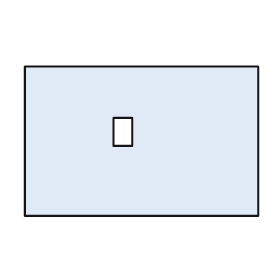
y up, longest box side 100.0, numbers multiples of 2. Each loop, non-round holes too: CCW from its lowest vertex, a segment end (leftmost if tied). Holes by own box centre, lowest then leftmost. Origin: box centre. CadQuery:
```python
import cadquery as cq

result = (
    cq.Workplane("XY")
    .moveTo(-50.0, -32.0)
    .lineTo(50.0, -32.0)
    .lineTo(50.0, 32.0)
    .lineTo(-50.0, 32.0)
    .close()
    .moveTo(-12.0, -2.0)
    .lineTo(-4.0, -2.0)
    .lineTo(-4.0, 10.0)
    .lineTo(-12.0, 10.0)
    .close()
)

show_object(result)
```